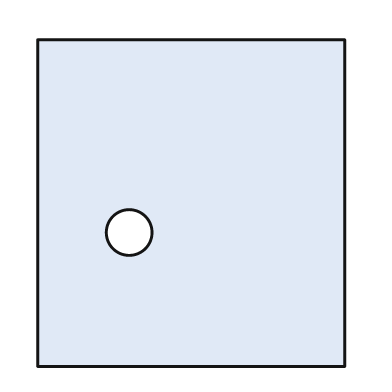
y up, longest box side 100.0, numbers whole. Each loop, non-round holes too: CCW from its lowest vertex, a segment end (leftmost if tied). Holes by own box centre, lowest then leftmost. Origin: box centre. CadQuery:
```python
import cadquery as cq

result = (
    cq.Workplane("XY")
    .moveTo(-47.0, -50.0)
    .lineTo(47.0, -50.0)
    .lineTo(47.0, 50.0)
    .lineTo(-47.0, 50.0)
    .close()
    .moveTo(-19.0, -9.0)
    .circle(7.0)
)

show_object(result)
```